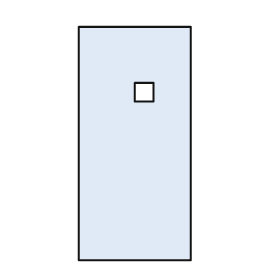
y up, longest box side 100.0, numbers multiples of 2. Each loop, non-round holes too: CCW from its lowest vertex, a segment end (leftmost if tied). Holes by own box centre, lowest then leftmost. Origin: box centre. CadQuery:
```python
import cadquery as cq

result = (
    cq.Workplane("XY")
    .moveTo(-24.0, -50.0)
    .lineTo(24.0, -50.0)
    .lineTo(24.0, 50.0)
    .lineTo(-24.0, 50.0)
    .close()
    .moveTo(0.0, 18.0)
    .lineTo(8.0, 18.0)
    .lineTo(8.0, 26.0)
    .lineTo(0.0, 26.0)
    .close()
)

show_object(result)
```